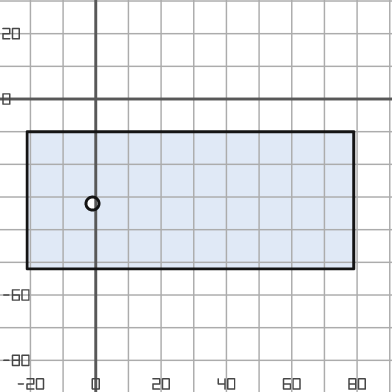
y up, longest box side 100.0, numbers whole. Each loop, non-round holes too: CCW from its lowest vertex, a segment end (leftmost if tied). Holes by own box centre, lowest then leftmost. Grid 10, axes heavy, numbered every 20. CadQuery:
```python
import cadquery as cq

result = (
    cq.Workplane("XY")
    .moveTo(-21.0, -52.0)
    .lineTo(79.0, -52.0)
    .lineTo(79.0, -10.0)
    .lineTo(-21.0, -10.0)
    .close()
    .moveTo(-1.0, -32.0)
    .circle(2.0)
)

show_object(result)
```